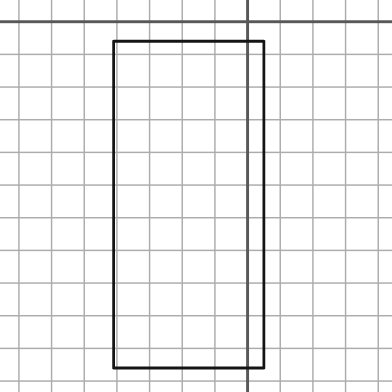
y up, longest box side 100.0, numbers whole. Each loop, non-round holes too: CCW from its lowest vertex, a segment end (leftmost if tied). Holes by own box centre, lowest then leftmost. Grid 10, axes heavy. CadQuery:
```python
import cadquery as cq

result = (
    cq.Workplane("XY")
    .moveTo(-41.0, -106.0)
    .lineTo(5.0, -106.0)
    .lineTo(5.0, -6.0)
    .lineTo(-41.0, -6.0)
    .close()
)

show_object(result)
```